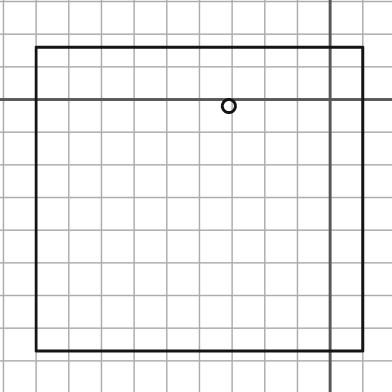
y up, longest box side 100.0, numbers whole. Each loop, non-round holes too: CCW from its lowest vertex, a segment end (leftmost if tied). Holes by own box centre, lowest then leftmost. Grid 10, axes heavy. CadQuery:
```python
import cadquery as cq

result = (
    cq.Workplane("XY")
    .moveTo(-90.0, -77.0)
    .lineTo(10.0, -77.0)
    .lineTo(10.0, 16.0)
    .lineTo(-90.0, 16.0)
    .close()
    .moveTo(-31.0, -2.0)
    .circle(2.0)
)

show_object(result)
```